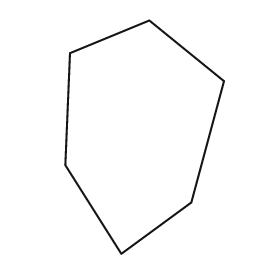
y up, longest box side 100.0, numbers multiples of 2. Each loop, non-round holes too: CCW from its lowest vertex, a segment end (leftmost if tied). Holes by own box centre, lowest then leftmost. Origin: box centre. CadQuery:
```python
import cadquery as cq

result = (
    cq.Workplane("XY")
    .moveTo(-10.0, -50.0)
    .lineTo(20.0, -28.0)
    .lineTo(34.0, 24.0)
    .lineTo(2.0, 50.0)
    .lineTo(-32.0, 36.0)
    .lineTo(-34.0, -12.0)
    .close()
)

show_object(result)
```